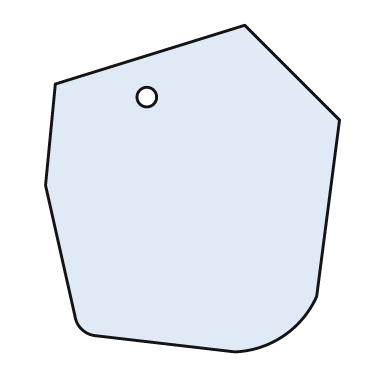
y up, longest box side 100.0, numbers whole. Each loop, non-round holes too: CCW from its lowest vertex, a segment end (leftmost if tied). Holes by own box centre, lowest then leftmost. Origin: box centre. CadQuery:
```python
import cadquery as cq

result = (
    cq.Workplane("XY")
    .moveTo(13.0, -50.0)
    .threePointArc((28.0, -45.0), (38.0, -33.0))
    .lineTo(45.0, 21.0)
    .lineTo(16.0, 50.0)
    .lineTo(-42.0, 32.0)
    .lineTo(-45.0, 1.0)
    .lineTo(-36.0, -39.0)
    .threePointArc((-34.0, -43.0), (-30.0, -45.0))
    .close()
    .moveTo(-14.0, 28.0)
    .circle(3.0)
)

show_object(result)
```